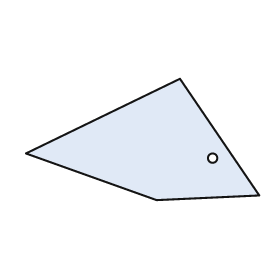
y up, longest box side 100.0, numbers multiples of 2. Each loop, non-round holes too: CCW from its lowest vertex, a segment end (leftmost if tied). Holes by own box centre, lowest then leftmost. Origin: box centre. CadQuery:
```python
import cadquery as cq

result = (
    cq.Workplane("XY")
    .moveTo(6.0, -26.0)
    .lineTo(50.0, -24.0)
    .lineTo(16.0, 26.0)
    .lineTo(-50.0, -6.0)
    .close()
    .moveTo(30.0, -8.0)
    .circle(2.0)
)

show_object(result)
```